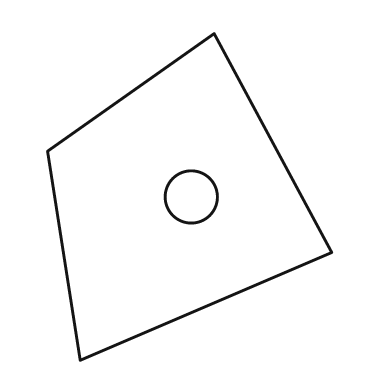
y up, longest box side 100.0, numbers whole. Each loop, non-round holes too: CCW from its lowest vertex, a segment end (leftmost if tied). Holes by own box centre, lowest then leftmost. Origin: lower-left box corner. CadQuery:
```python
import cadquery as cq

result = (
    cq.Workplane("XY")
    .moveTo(10.0, 0.0)
    .lineTo(87.0, 33.0)
    .lineTo(51.0, 100.0)
    .lineTo(0.0, 64.0)
    .close()
    .moveTo(44.0, 50.0)
    .circle(8.0)
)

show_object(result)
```